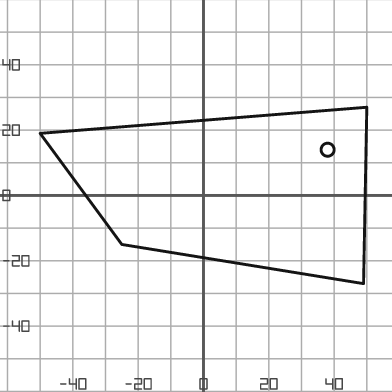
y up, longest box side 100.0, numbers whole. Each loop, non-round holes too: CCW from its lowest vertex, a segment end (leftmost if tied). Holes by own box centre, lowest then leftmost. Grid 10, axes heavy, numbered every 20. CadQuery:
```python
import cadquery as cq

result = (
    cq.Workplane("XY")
    .moveTo(49.0, -27.0)
    .lineTo(50.0, 27.0)
    .lineTo(-50.0, 19.0)
    .lineTo(-25.0, -15.0)
    .close()
    .moveTo(38.0, 14.0)
    .circle(2.0)
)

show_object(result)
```